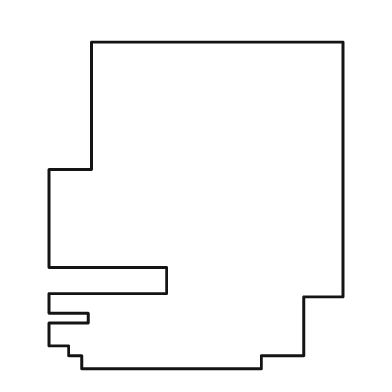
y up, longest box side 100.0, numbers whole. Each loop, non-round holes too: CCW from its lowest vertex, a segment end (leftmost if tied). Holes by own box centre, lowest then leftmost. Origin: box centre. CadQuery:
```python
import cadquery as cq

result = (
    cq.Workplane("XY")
    .moveTo(-35.0, -50.0)
    .lineTo(20.0, -50.0)
    .lineTo(20.0, -46.0)
    .lineTo(33.0, -46.0)
    .lineTo(33.0, -28.0)
    .lineTo(45.0, -28.0)
    .lineTo(45.0, 50.0)
    .lineTo(-32.0, 50.0)
    .lineTo(-32.0, 11.0)
    .lineTo(-45.0, 11.0)
    .lineTo(-45.0, -19.0)
    .lineTo(-9.0, -19.0)
    .lineTo(-9.0, -27.0)
    .lineTo(-45.0, -27.0)
    .lineTo(-45.0, -33.0)
    .lineTo(-33.0, -33.0)
    .lineTo(-33.0, -36.0)
    .lineTo(-45.0, -36.0)
    .lineTo(-45.0, -43.0)
    .lineTo(-39.0, -43.0)
    .lineTo(-39.0, -46.0)
    .lineTo(-35.0, -46.0)
    .close()
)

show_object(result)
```